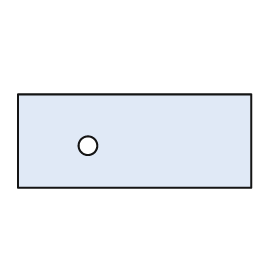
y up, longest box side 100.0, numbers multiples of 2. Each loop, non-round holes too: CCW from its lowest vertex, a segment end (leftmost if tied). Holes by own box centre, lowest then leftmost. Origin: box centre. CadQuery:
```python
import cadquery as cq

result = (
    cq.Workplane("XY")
    .moveTo(-50.0, -20.0)
    .lineTo(50.0, -20.0)
    .lineTo(50.0, 20.0)
    .lineTo(-50.0, 20.0)
    .close()
    .moveTo(-20.0, -2.0)
    .circle(4.0)
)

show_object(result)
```